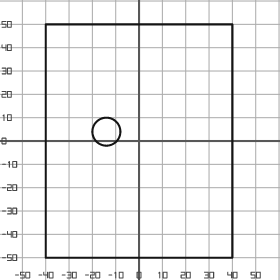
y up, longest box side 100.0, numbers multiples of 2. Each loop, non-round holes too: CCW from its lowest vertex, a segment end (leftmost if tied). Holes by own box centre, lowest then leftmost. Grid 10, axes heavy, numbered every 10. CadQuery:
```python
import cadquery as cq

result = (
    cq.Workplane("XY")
    .moveTo(-40.0, -50.0)
    .lineTo(40.0, -50.0)
    .lineTo(40.0, 50.0)
    .lineTo(-40.0, 50.0)
    .close()
    .moveTo(-14.0, 4.0)
    .circle(6.0)
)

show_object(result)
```